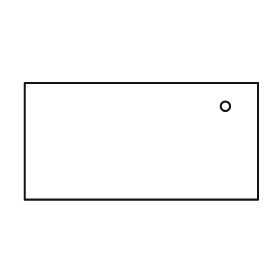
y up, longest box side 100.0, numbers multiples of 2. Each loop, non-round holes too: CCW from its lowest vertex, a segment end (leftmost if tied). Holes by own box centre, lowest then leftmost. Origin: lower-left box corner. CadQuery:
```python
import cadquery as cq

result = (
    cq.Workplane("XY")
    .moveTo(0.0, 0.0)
    .lineTo(100.0, 0.0)
    .lineTo(100.0, 50.0)
    .lineTo(0.0, 50.0)
    .close()
    .moveTo(86.0, 40.0)
    .circle(2.0)
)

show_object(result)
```